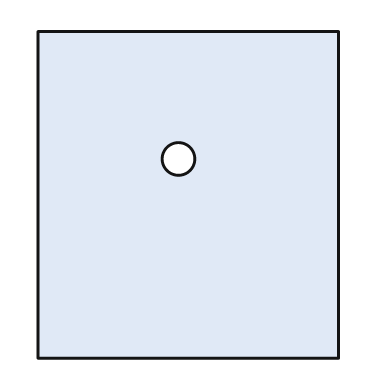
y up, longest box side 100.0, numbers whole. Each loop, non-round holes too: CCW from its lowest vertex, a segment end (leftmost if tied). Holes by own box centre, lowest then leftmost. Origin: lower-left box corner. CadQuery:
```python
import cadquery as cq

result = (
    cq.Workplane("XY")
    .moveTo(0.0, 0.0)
    .lineTo(92.0, 0.0)
    .lineTo(92.0, 100.0)
    .lineTo(0.0, 100.0)
    .close()
    .moveTo(43.0, 61.0)
    .circle(5.0)
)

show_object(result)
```